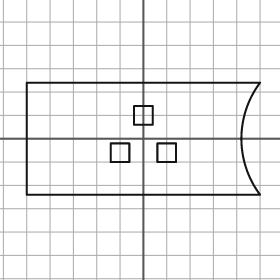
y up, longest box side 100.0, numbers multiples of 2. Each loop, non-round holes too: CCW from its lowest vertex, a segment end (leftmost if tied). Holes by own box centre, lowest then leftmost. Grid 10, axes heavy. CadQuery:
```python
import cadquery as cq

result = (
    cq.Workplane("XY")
    .moveTo(-50.0, -24.0)
    .lineTo(50.0, -24.0)
    .threePointArc((42.0, 0.0), (50.0, 24.0))
    .lineTo(-50.0, 24.0)
    .close()
    .moveTo(-14.0, -10.0)
    .lineTo(-6.0, -10.0)
    .lineTo(-6.0, -2.0)
    .lineTo(-14.0, -2.0)
    .close()
    .moveTo(6.0, -10.0)
    .lineTo(14.0, -10.0)
    .lineTo(14.0, -2.0)
    .lineTo(6.0, -2.0)
    .close()
    .moveTo(-4.0, 6.0)
    .lineTo(4.0, 6.0)
    .lineTo(4.0, 14.0)
    .lineTo(-4.0, 14.0)
    .close()
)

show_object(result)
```